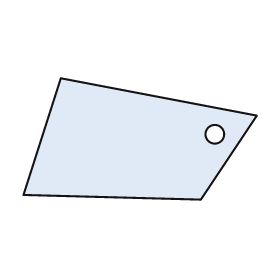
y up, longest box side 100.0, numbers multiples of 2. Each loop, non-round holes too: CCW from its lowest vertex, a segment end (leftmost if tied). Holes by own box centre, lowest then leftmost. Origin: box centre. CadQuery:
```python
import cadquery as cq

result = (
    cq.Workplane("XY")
    .moveTo(26.0, -26.0)
    .lineTo(50.0, 10.0)
    .lineTo(-34.0, 26.0)
    .lineTo(-50.0, -24.0)
    .close()
    .moveTo(32.0, 2.0)
    .circle(4.0)
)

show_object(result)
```